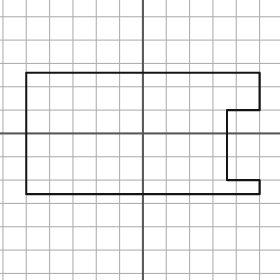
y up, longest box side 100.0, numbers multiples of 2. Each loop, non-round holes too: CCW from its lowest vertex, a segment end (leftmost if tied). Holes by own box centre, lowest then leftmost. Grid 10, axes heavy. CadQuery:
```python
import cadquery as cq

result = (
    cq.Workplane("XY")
    .moveTo(-50.0, -26.0)
    .lineTo(50.0, -26.0)
    .lineTo(50.0, -20.0)
    .lineTo(36.0, -20.0)
    .lineTo(36.0, 10.0)
    .lineTo(50.0, 10.0)
    .lineTo(50.0, 26.0)
    .lineTo(-50.0, 26.0)
    .close()
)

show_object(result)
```